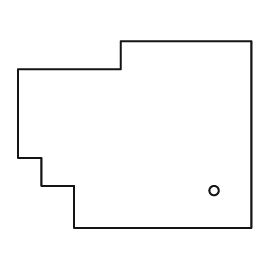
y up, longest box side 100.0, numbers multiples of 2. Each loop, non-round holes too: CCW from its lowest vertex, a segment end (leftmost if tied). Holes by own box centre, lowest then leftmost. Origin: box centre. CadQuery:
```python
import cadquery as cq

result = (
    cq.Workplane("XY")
    .moveTo(-26.0, -40.0)
    .lineTo(50.0, -40.0)
    .lineTo(50.0, 40.0)
    .lineTo(-6.0, 40.0)
    .lineTo(-6.0, 28.0)
    .lineTo(-50.0, 28.0)
    .lineTo(-50.0, -10.0)
    .lineTo(-40.0, -10.0)
    .lineTo(-40.0, -22.0)
    .lineTo(-26.0, -22.0)
    .close()
    .moveTo(34.0, -24.0)
    .circle(2.0)
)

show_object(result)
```